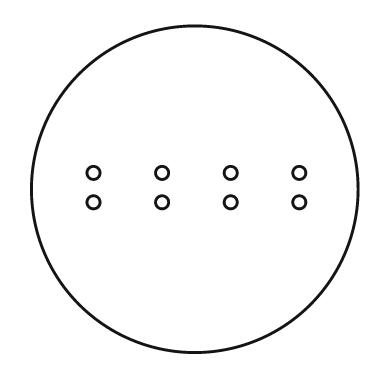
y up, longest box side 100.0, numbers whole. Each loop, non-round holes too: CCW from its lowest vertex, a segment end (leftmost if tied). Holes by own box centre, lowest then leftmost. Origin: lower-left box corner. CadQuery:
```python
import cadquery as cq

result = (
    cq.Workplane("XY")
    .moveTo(50.0, 50.0)
    .circle(50.0)
    .moveTo(19.0, 46.0)
    .circle(2.0)
    .moveTo(40.0, 46.0)
    .circle(2.0)
    .moveTo(61.0, 46.0)
    .circle(2.0)
    .moveTo(82.0, 46.0)
    .circle(2.0)
    .moveTo(19.0, 55.0)
    .circle(2.0)
    .moveTo(40.0, 55.0)
    .circle(2.0)
    .moveTo(61.0, 55.0)
    .circle(2.0)
    .moveTo(82.0, 55.0)
    .circle(2.0)
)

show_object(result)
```